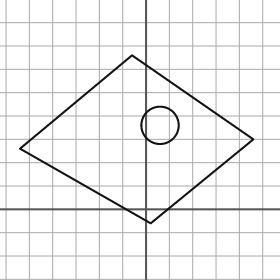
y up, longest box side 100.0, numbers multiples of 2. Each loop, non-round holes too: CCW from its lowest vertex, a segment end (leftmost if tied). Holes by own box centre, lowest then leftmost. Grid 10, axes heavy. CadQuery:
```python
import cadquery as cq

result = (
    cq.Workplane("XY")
    .moveTo(2.0, -6.0)
    .lineTo(46.0, 30.0)
    .lineTo(-6.0, 66.0)
    .lineTo(-54.0, 26.0)
    .close()
    .moveTo(6.0, 36.0)
    .circle(8.0)
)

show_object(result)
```